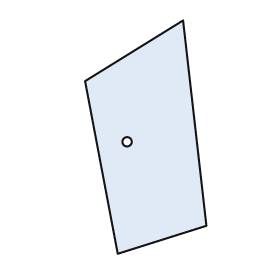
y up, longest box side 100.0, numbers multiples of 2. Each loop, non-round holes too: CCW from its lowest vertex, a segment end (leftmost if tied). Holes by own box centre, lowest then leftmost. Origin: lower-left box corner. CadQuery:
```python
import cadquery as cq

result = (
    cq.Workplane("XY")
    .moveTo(14.0, 0.0)
    .lineTo(52.0, 12.0)
    .lineTo(42.0, 100.0)
    .lineTo(0.0, 74.0)
    .close()
    .moveTo(18.0, 48.0)
    .circle(2.0)
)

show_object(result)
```